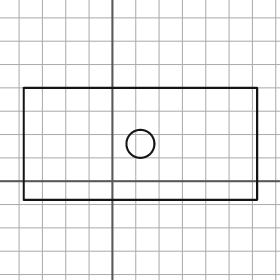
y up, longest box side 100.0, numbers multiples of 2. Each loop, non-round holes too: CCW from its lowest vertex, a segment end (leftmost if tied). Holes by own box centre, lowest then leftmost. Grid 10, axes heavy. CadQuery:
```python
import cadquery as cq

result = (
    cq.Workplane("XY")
    .moveTo(-38.0, -8.0)
    .lineTo(62.0, -8.0)
    .lineTo(62.0, 40.0)
    .lineTo(-38.0, 40.0)
    .close()
    .moveTo(12.0, 16.0)
    .circle(6.0)
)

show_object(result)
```